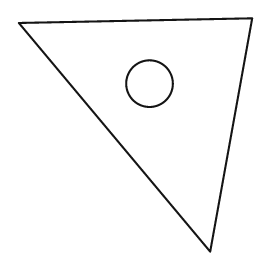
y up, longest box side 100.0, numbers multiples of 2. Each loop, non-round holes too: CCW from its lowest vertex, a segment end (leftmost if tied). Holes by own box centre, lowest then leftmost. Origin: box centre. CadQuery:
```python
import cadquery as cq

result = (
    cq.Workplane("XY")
    .moveTo(32.0, -50.0)
    .lineTo(50.0, 50.0)
    .lineTo(-50.0, 48.0)
    .close()
    .moveTo(6.0, 22.0)
    .circle(10.0)
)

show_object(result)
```